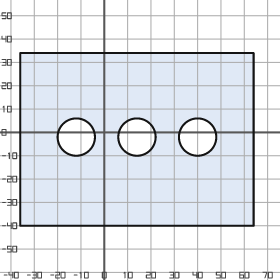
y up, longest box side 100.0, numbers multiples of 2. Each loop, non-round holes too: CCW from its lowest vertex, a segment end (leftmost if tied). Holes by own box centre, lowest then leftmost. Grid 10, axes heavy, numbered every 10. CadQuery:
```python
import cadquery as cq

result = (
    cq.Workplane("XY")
    .moveTo(-36.0, -40.0)
    .lineTo(64.0, -40.0)
    .lineTo(64.0, 34.0)
    .lineTo(-36.0, 34.0)
    .close()
    .moveTo(-12.0, -2.0)
    .circle(8.0)
    .moveTo(14.0, -2.0)
    .circle(8.0)
    .moveTo(40.0, -2.0)
    .circle(8.0)
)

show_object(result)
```